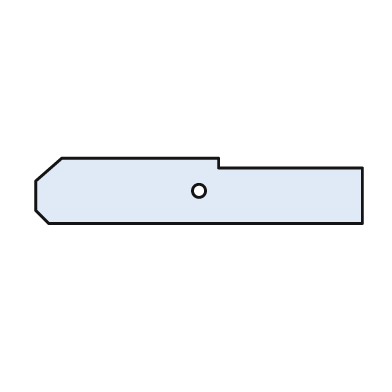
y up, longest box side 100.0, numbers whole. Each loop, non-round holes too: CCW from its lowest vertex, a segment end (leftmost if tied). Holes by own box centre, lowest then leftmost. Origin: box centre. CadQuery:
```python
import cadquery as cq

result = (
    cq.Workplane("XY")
    .moveTo(-46.0, -10.0)
    .lineTo(50.0, -10.0)
    .lineTo(50.0, 7.0)
    .lineTo(6.0, 7.0)
    .lineTo(6.0, 10.0)
    .lineTo(-42.0, 10.0)
    .lineTo(-50.0, 3.0)
    .lineTo(-50.0, -6.0)
    .close()
    .moveTo(0.0, 0.0)
    .circle(2.0)
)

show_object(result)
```